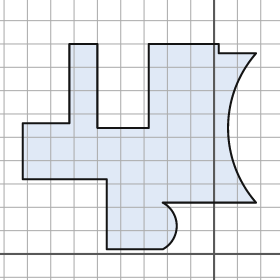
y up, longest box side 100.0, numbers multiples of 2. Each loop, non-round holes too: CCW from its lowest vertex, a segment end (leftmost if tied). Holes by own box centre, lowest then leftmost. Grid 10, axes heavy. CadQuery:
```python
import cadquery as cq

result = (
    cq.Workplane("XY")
    .moveTo(-46.0, 2.0)
    .lineTo(-22.0, 2.0)
    .threePointArc((-16.0, 12.0), (-22.0, 22.0))
    .lineTo(18.0, 22.0)
    .threePointArc((6.0, 54.0), (18.0, 86.0))
    .lineTo(2.0, 86.0)
    .lineTo(2.0, 90.0)
    .lineTo(-28.0, 90.0)
    .lineTo(-28.0, 54.0)
    .lineTo(-50.0, 54.0)
    .lineTo(-50.0, 90.0)
    .lineTo(-62.0, 90.0)
    .lineTo(-62.0, 56.0)
    .lineTo(-82.0, 56.0)
    .lineTo(-82.0, 32.0)
    .lineTo(-46.0, 32.0)
    .close()
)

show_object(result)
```